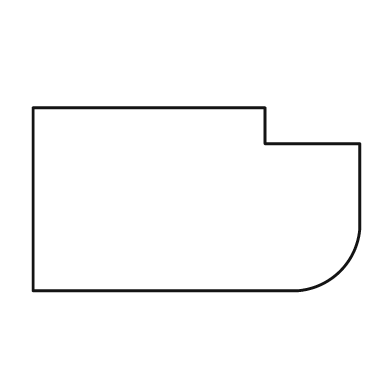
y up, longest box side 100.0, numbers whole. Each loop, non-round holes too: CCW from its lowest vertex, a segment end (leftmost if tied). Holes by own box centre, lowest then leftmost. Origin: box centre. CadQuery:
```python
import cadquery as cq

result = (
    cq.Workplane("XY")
    .moveTo(-50.0, -28.0)
    .lineTo(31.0, -28.0)
    .threePointArc((44.0, -22.0), (50.0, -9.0))
    .lineTo(50.0, 17.0)
    .lineTo(21.0, 17.0)
    .lineTo(21.0, 28.0)
    .lineTo(-50.0, 28.0)
    .close()
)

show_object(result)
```